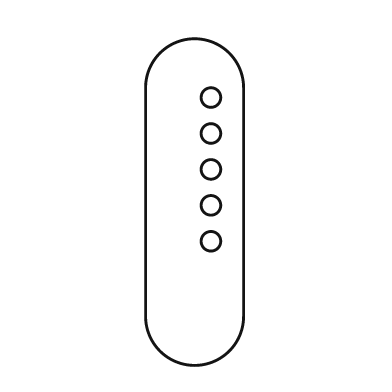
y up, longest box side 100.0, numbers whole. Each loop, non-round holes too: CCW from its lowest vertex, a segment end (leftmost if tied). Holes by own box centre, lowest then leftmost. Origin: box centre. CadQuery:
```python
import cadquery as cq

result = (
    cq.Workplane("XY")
    .moveTo(-15.0, -35.0)
    .threePointArc((0.0, -50.0), (15.0, -35.0))
    .lineTo(15.0, 35.0)
    .threePointArc((0.0, 50.0), (-15.0, 35.0))
    .close()
    .moveTo(5.0, -12.0)
    .circle(3.0)
    .moveTo(5.0, -1.0)
    .circle(3.0)
    .moveTo(5.0, 10.0)
    .circle(3.0)
    .moveTo(5.0, 21.0)
    .circle(3.0)
    .moveTo(5.0, 32.0)
    .circle(3.0)
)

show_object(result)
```